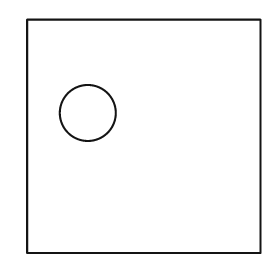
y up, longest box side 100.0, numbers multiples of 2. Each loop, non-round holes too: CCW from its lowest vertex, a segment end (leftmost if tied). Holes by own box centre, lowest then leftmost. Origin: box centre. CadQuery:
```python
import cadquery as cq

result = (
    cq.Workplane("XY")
    .moveTo(-50.0, -50.0)
    .lineTo(50.0, -50.0)
    .lineTo(50.0, 50.0)
    .lineTo(-50.0, 50.0)
    .close()
    .moveTo(-24.0, 10.0)
    .circle(12.0)
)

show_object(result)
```